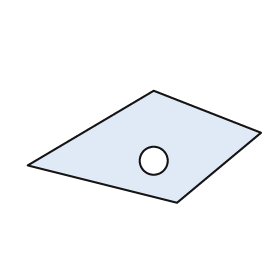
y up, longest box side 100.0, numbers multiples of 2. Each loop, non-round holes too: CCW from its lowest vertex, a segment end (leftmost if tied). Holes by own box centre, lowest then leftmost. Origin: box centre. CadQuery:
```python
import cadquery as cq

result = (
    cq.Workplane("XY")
    .moveTo(14.0, -24.0)
    .lineTo(50.0, 6.0)
    .lineTo(4.0, 24.0)
    .lineTo(-50.0, -8.0)
    .close()
    .moveTo(4.0, -6.0)
    .circle(6.0)
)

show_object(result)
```